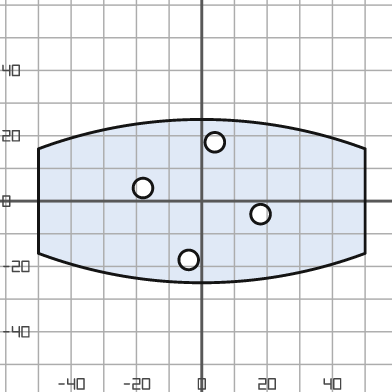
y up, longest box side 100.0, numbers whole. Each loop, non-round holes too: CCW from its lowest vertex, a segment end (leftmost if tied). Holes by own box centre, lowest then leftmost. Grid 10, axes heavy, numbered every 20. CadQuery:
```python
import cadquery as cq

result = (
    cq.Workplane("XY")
    .moveTo(-50.0, -16.0)
    .threePointArc((0.0, -25.0), (50.0, -16.0))
    .lineTo(50.0, 16.0)
    .threePointArc((0.0, 25.0), (-50.0, 16.0))
    .close()
    .moveTo(-4.0, -18.0)
    .circle(3.0)
    .moveTo(18.0, -4.0)
    .circle(3.0)
    .moveTo(-18.0, 4.0)
    .circle(3.0)
    .moveTo(4.0, 18.0)
    .circle(3.0)
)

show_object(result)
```